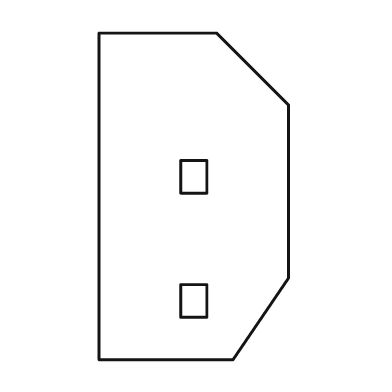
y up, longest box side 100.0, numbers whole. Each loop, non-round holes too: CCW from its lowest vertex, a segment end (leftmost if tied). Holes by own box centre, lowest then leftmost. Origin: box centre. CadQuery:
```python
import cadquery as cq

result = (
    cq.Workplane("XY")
    .moveTo(-29.0, -50.0)
    .lineTo(12.0, -50.0)
    .lineTo(29.0, -25.0)
    .lineTo(29.0, 28.0)
    .lineTo(7.0, 50.0)
    .lineTo(-29.0, 50.0)
    .close()
    .moveTo(-4.0, -37.0)
    .lineTo(4.0, -37.0)
    .lineTo(4.0, -27.0)
    .lineTo(-4.0, -27.0)
    .close()
    .moveTo(-4.0, 1.0)
    .lineTo(4.0, 1.0)
    .lineTo(4.0, 11.0)
    .lineTo(-4.0, 11.0)
    .close()
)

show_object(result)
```